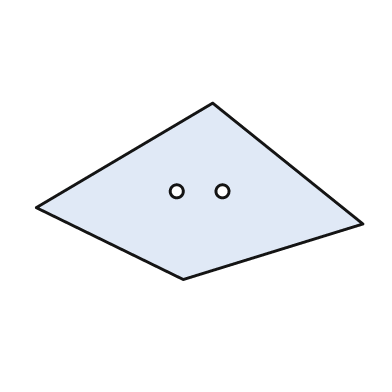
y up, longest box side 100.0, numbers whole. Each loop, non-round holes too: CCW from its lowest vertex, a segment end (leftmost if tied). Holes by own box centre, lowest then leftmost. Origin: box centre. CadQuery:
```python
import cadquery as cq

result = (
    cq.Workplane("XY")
    .moveTo(-5.0, -27.0)
    .lineTo(50.0, -10.0)
    .lineTo(4.0, 27.0)
    .lineTo(-50.0, -5.0)
    .close()
    .moveTo(-7.0, 0.0)
    .circle(2.0)
    .moveTo(7.0, 0.0)
    .circle(2.0)
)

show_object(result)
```